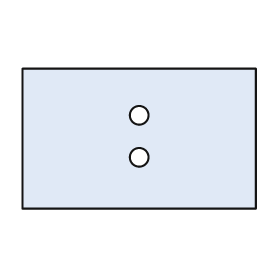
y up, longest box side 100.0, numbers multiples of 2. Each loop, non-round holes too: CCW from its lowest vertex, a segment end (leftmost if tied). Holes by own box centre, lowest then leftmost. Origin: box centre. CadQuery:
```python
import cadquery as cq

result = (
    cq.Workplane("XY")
    .moveTo(-50.0, -30.0)
    .lineTo(50.0, -30.0)
    .lineTo(50.0, 30.0)
    .lineTo(-50.0, 30.0)
    .close()
    .moveTo(0.0, -8.0)
    .circle(4.0)
    .moveTo(0.0, 10.0)
    .circle(4.0)
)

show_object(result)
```